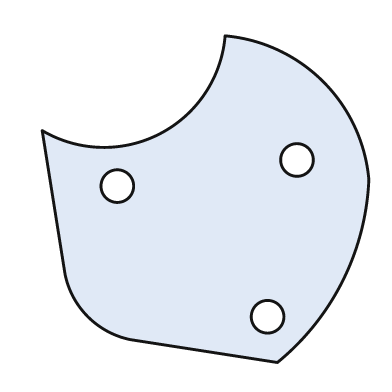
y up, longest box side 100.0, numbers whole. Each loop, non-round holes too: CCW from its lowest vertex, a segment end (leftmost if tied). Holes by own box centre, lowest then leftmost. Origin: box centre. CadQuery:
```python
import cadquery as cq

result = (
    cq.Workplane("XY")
    .moveTo(22.0, -50.0)
    .threePointArc((42.0, -25.0), (50.0, 6.0))
    .threePointArc((36.0, 36.0), (6.0, 50.0))
    .threePointArc((-14.0, 20.0), (-50.0, 21.0))
    .lineTo(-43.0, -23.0)
    .threePointArc((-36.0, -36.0), (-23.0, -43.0))
    .close()
    .moveTo(19.0, -36.0)
    .circle(5.0)
    .moveTo(-27.0, 4.0)
    .circle(5.0)
    .moveTo(28.0, 12.0)
    .circle(5.0)
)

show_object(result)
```